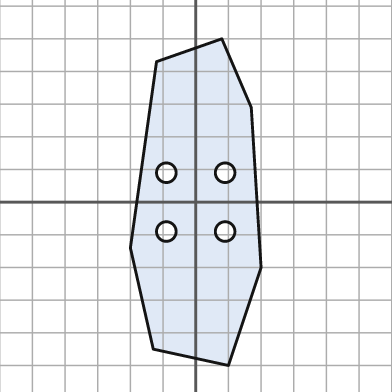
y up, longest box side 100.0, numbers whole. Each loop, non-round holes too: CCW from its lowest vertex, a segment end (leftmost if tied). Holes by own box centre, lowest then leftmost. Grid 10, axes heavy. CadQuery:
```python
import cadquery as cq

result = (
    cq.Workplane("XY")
    .moveTo(10.0, -50.0)
    .lineTo(20.0, -20.0)
    .lineTo(17.0, 29.0)
    .lineTo(8.0, 50.0)
    .lineTo(-12.0, 43.0)
    .lineTo(-20.0, -14.0)
    .lineTo(-13.0, -45.0)
    .close()
    .moveTo(-9.0, -9.0)
    .circle(3.0)
    .moveTo(9.0, -9.0)
    .circle(3.0)
    .moveTo(-9.0, 9.0)
    .circle(3.0)
    .moveTo(9.0, 9.0)
    .circle(3.0)
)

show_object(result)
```